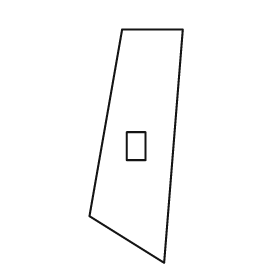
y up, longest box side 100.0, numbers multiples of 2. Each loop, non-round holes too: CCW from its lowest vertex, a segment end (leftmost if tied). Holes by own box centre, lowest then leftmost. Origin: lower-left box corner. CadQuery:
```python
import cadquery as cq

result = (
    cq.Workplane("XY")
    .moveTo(32.0, 0.0)
    .lineTo(40.0, 100.0)
    .lineTo(14.0, 100.0)
    .lineTo(0.0, 20.0)
    .close()
    .moveTo(16.0, 44.0)
    .lineTo(24.0, 44.0)
    .lineTo(24.0, 56.0)
    .lineTo(16.0, 56.0)
    .close()
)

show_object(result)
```